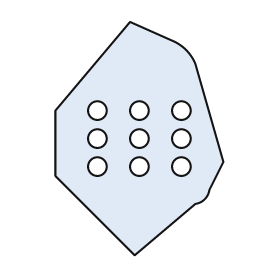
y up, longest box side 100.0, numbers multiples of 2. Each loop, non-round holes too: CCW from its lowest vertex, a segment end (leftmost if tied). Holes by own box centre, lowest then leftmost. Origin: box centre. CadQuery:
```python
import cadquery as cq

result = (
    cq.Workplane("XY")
    .moveTo(-2.0, -50.0)
    .lineTo(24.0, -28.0)
    .threePointArc((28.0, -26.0), (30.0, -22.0))
    .lineTo(36.0, -10.0)
    .lineTo(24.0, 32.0)
    .threePointArc((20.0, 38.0), (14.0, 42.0))
    .lineTo(-4.0, 50.0)
    .lineTo(-36.0, 12.0)
    .lineTo(-36.0, -16.0)
    .close()
    .moveTo(-18.0, -12.0)
    .circle(4.0)
    .moveTo(0.0, -12.0)
    .circle(4.0)
    .moveTo(18.0, -12.0)
    .circle(4.0)
    .moveTo(-18.0, 0.0)
    .circle(4.0)
    .moveTo(0.0, 0.0)
    .circle(4.0)
    .moveTo(18.0, 0.0)
    .circle(4.0)
    .moveTo(-18.0, 12.0)
    .circle(4.0)
    .moveTo(0.0, 12.0)
    .circle(4.0)
    .moveTo(18.0, 12.0)
    .circle(4.0)
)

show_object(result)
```